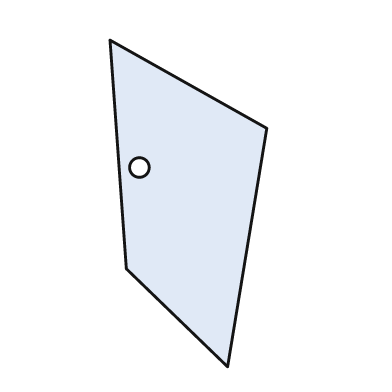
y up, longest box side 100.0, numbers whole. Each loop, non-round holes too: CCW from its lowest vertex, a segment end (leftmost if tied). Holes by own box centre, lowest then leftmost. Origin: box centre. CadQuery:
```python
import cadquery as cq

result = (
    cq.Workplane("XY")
    .moveTo(12.0, -50.0)
    .lineTo(24.0, 23.0)
    .lineTo(-24.0, 50.0)
    .lineTo(-19.0, -20.0)
    .close()
    .moveTo(-15.0, 11.0)
    .circle(3.0)
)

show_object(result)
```